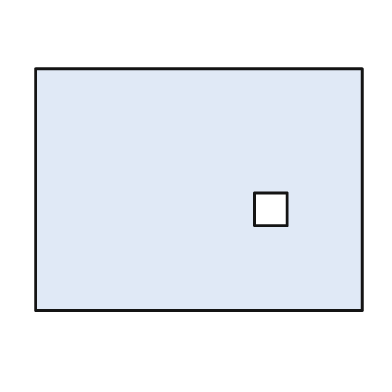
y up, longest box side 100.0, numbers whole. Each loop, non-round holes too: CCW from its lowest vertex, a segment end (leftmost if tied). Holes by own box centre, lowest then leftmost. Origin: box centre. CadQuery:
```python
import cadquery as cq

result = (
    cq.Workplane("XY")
    .moveTo(-50.0, -37.0)
    .lineTo(50.0, -37.0)
    .lineTo(50.0, 37.0)
    .lineTo(-50.0, 37.0)
    .close()
    .moveTo(17.0, -11.0)
    .lineTo(27.0, -11.0)
    .lineTo(27.0, -1.0)
    .lineTo(17.0, -1.0)
    .close()
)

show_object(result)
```